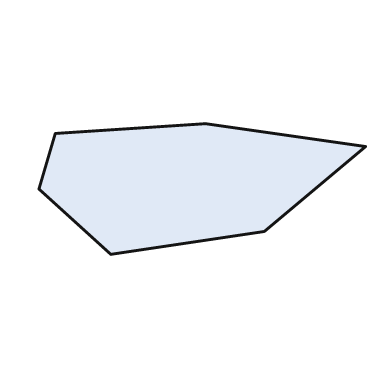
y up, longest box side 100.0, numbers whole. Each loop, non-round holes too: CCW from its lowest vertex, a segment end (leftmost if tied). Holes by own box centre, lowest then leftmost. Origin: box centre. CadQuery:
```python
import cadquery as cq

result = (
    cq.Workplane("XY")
    .moveTo(-28.0, -20.0)
    .lineTo(19.0, -13.0)
    .lineTo(50.0, 13.0)
    .lineTo(1.0, 20.0)
    .lineTo(-45.0, 17.0)
    .lineTo(-50.0, 0.0)
    .close()
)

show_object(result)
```